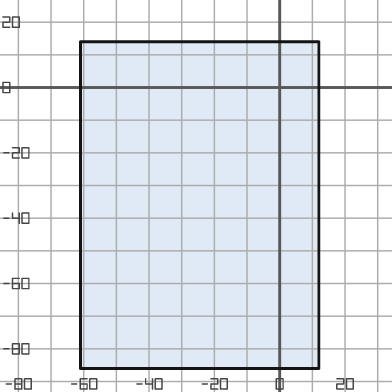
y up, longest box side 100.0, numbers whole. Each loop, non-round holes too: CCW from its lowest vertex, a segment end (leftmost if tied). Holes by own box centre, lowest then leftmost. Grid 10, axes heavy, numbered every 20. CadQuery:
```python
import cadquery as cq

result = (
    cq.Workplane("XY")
    .moveTo(-61.0, -86.0)
    .lineTo(12.0, -86.0)
    .lineTo(12.0, 14.0)
    .lineTo(-61.0, 14.0)
    .close()
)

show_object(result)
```